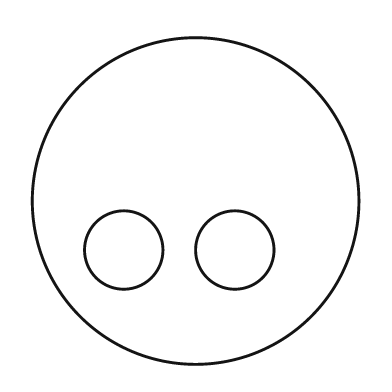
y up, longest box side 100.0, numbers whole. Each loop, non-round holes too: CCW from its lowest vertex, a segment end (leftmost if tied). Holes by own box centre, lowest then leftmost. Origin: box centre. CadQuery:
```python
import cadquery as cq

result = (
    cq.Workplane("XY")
    .moveTo(0.0, 0.0)
    .circle(50.0)
    .moveTo(-22.0, -15.0)
    .circle(12.0)
    .moveTo(12.0, -15.0)
    .circle(12.0)
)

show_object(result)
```